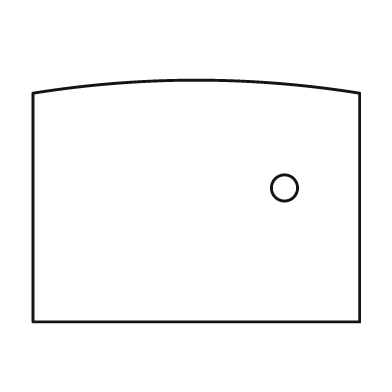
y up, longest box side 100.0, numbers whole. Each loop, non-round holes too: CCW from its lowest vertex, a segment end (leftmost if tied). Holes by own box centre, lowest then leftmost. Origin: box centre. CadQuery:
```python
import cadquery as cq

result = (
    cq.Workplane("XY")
    .moveTo(-50.0, -37.0)
    .lineTo(50.0, -37.0)
    .lineTo(50.0, 33.0)
    .threePointArc((0.0, 37.0), (-50.0, 33.0))
    .close()
    .moveTo(27.0, 4.0)
    .circle(4.0)
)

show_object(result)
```